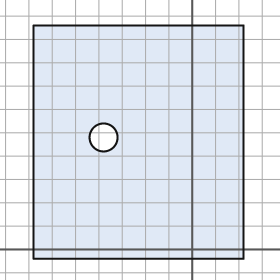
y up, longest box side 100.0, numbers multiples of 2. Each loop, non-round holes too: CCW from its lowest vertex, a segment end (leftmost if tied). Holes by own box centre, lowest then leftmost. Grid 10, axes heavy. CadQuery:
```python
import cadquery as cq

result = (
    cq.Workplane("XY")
    .moveTo(-68.0, -4.0)
    .lineTo(22.0, -4.0)
    .lineTo(22.0, 96.0)
    .lineTo(-68.0, 96.0)
    .close()
    .moveTo(-38.0, 48.0)
    .circle(6.0)
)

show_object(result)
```